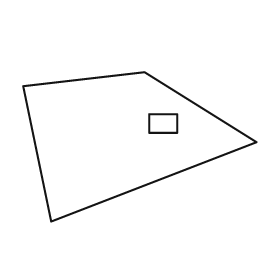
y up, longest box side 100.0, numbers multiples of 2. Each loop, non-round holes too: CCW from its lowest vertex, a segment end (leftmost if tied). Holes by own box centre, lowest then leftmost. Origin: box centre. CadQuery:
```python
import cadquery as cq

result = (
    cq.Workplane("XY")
    .moveTo(-38.0, -32.0)
    .lineTo(50.0, 2.0)
    .lineTo(2.0, 32.0)
    .lineTo(-50.0, 26.0)
    .close()
    .moveTo(4.0, 6.0)
    .lineTo(16.0, 6.0)
    .lineTo(16.0, 14.0)
    .lineTo(4.0, 14.0)
    .close()
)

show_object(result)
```